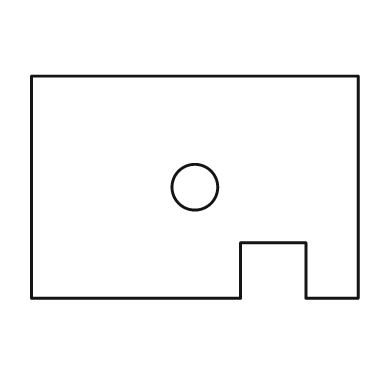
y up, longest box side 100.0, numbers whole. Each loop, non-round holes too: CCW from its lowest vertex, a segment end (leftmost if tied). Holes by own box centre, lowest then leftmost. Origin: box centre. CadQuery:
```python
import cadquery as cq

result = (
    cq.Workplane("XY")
    .moveTo(-50.0, -34.0)
    .lineTo(14.0, -34.0)
    .lineTo(14.0, -17.0)
    .lineTo(34.0, -17.0)
    .lineTo(34.0, -34.0)
    .lineTo(50.0, -34.0)
    .lineTo(50.0, 34.0)
    .lineTo(-50.0, 34.0)
    .close()
    .moveTo(0.0, 0.0)
    .circle(7.0)
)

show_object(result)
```